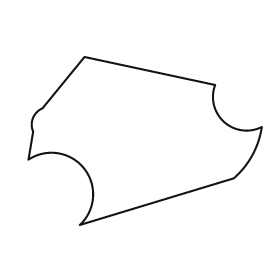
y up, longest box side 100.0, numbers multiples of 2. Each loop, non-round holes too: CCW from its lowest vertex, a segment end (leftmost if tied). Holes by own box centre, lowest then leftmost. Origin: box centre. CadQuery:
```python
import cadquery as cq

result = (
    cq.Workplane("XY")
    .moveTo(-28.0, -36.0)
    .lineTo(38.0, -16.0)
    .threePointArc((46.0, -6.0), (50.0, 6.0))
    .threePointArc((34.0, 8.0), (30.0, 24.0))
    .lineTo(-26.0, 36.0)
    .lineTo(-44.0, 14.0)
    .threePointArc((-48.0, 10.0), (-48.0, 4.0))
    .lineTo(-50.0, -8.0)
    .threePointArc((-26.0, -12.0), (-28.0, -36.0))
    .close()
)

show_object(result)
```